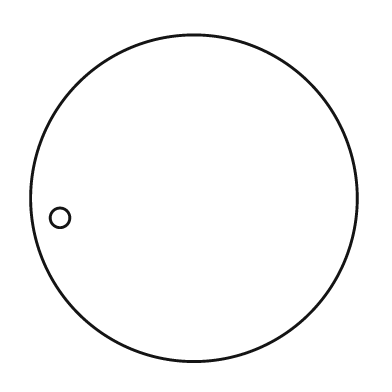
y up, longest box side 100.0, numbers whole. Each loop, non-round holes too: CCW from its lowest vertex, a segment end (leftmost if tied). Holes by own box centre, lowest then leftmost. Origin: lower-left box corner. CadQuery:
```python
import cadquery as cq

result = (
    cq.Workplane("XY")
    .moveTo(50.0, 50.0)
    .circle(50.0)
    .moveTo(9.0, 44.0)
    .circle(3.0)
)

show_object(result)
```